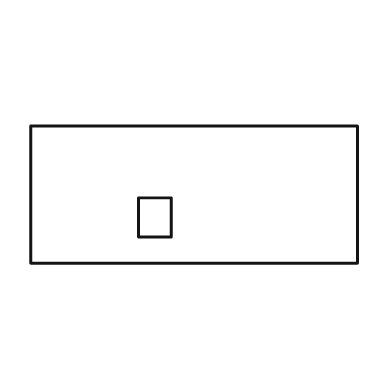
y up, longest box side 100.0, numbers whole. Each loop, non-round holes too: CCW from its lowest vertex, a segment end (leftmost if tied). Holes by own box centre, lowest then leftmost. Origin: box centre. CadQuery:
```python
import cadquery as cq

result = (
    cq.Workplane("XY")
    .moveTo(-50.0, -21.0)
    .lineTo(50.0, -21.0)
    .lineTo(50.0, 21.0)
    .lineTo(-50.0, 21.0)
    .close()
    .moveTo(-17.0, -13.0)
    .lineTo(-7.0, -13.0)
    .lineTo(-7.0, -1.0)
    .lineTo(-17.0, -1.0)
    .close()
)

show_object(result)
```